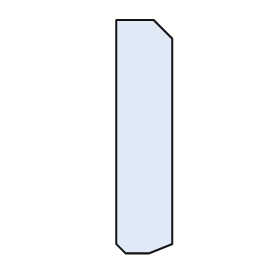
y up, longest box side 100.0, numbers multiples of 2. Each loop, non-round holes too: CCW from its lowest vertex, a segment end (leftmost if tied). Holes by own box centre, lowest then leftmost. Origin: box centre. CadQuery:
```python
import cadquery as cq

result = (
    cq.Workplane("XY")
    .moveTo(-8.0, -50.0)
    .lineTo(2.0, -50.0)
    .lineTo(12.0, -46.0)
    .lineTo(12.0, 42.0)
    .lineTo(4.0, 50.0)
    .lineTo(-12.0, 50.0)
    .lineTo(-12.0, -46.0)
    .close()
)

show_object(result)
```